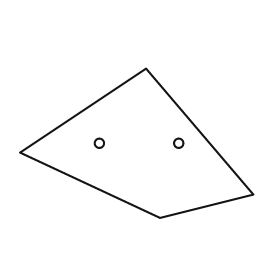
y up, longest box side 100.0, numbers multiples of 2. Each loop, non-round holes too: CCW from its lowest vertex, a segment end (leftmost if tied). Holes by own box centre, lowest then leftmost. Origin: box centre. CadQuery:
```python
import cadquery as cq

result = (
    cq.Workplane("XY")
    .moveTo(10.0, -32.0)
    .lineTo(50.0, -22.0)
    .lineTo(4.0, 32.0)
    .lineTo(-50.0, -4.0)
    .close()
    .moveTo(-16.0, 0.0)
    .circle(2.0)
    .moveTo(18.0, 0.0)
    .circle(2.0)
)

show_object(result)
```